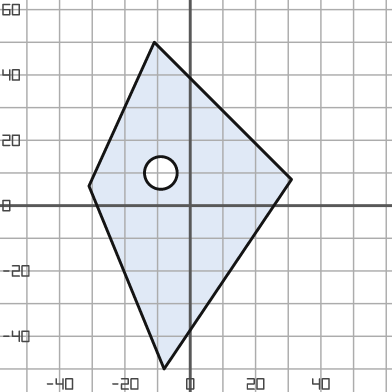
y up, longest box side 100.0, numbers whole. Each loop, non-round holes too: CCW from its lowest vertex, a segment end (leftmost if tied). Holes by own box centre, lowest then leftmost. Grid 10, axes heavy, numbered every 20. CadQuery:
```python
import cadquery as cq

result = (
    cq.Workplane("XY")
    .moveTo(-8.0, -50.0)
    .lineTo(31.0, 8.0)
    .lineTo(-11.0, 50.0)
    .lineTo(-31.0, 6.0)
    .close()
    .moveTo(-9.0, 10.0)
    .circle(5.0)
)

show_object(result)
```